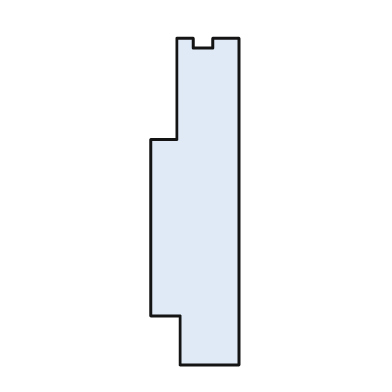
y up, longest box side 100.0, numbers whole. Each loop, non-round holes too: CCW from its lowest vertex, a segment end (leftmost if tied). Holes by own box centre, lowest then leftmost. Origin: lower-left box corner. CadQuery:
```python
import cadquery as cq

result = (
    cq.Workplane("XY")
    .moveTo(9.0, 0.0)
    .lineTo(27.0, 0.0)
    .lineTo(27.0, 100.0)
    .lineTo(19.0, 100.0)
    .lineTo(19.0, 97.0)
    .lineTo(13.0, 97.0)
    .lineTo(13.0, 100.0)
    .lineTo(8.0, 100.0)
    .lineTo(8.0, 69.0)
    .lineTo(0.0, 69.0)
    .lineTo(0.0, 15.0)
    .lineTo(9.0, 15.0)
    .close()
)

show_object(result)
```